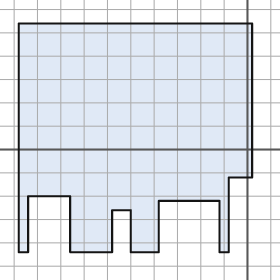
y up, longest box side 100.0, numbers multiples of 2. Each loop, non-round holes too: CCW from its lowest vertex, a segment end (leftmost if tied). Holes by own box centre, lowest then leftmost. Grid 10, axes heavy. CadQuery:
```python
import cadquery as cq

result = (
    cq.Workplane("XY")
    .moveTo(-98.0, -44.0)
    .lineTo(-94.0, -44.0)
    .lineTo(-94.0, -20.0)
    .lineTo(-76.0, -20.0)
    .lineTo(-76.0, -44.0)
    .lineTo(-58.0, -44.0)
    .lineTo(-58.0, -26.0)
    .lineTo(-50.0, -26.0)
    .lineTo(-50.0, -44.0)
    .lineTo(-38.0, -44.0)
    .lineTo(-38.0, -22.0)
    .lineTo(-12.0, -22.0)
    .lineTo(-12.0, -44.0)
    .lineTo(-8.0, -44.0)
    .lineTo(-8.0, -12.0)
    .lineTo(2.0, -12.0)
    .lineTo(2.0, 54.0)
    .lineTo(-98.0, 54.0)
    .close()
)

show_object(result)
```